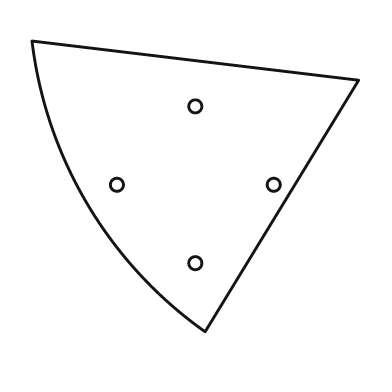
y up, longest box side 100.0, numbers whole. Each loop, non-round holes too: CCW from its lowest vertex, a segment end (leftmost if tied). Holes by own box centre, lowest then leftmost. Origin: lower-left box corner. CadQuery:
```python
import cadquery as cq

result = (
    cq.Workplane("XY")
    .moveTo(53.0, 0.0)
    .lineTo(100.0, 77.0)
    .lineTo(0.0, 89.0)
    .threePointArc((17.0, 39.0), (53.0, 0.0))
    .close()
    .moveTo(50.0, 21.0)
    .circle(2.0)
    .moveTo(26.0, 45.0)
    .circle(2.0)
    .moveTo(74.0, 45.0)
    .circle(2.0)
    .moveTo(50.0, 69.0)
    .circle(2.0)
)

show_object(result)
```